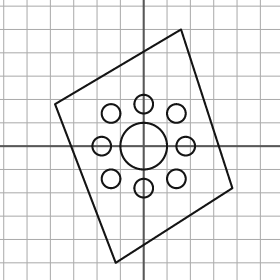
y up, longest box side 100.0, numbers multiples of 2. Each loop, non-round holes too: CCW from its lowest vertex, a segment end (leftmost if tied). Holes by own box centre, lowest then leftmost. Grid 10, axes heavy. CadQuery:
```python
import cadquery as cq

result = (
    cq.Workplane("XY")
    .moveTo(-12.0, -50.0)
    .lineTo(38.0, -18.0)
    .lineTo(16.0, 50.0)
    .lineTo(-38.0, 18.0)
    .close()
    .moveTo(0.0, -18.0)
    .circle(4.0)
    .moveTo(-14.0, -14.0)
    .circle(4.0)
    .moveTo(14.0, -14.0)
    .circle(4.0)
    .moveTo(-18.0, 0.0)
    .circle(4.0)
    .moveTo(0.0, 0.0)
    .circle(10.0)
    .moveTo(18.0, 0.0)
    .circle(4.0)
    .moveTo(-14.0, 14.0)
    .circle(4.0)
    .moveTo(14.0, 14.0)
    .circle(4.0)
    .moveTo(0.0, 18.0)
    .circle(4.0)
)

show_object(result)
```